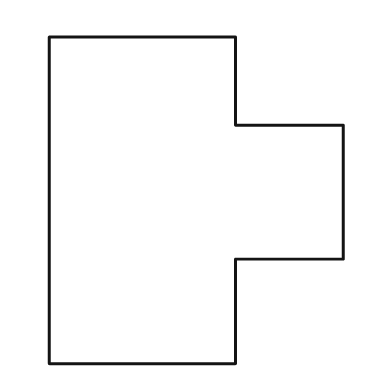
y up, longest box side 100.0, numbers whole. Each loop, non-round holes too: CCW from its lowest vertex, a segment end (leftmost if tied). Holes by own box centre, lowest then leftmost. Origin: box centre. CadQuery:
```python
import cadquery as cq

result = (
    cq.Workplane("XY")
    .moveTo(-45.0, -50.0)
    .lineTo(12.0, -50.0)
    .lineTo(12.0, -18.0)
    .lineTo(45.0, -18.0)
    .lineTo(45.0, 23.0)
    .lineTo(12.0, 23.0)
    .lineTo(12.0, 50.0)
    .lineTo(-45.0, 50.0)
    .close()
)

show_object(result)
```